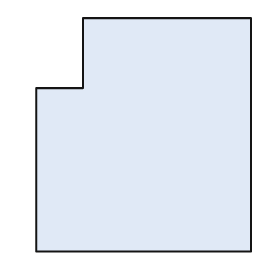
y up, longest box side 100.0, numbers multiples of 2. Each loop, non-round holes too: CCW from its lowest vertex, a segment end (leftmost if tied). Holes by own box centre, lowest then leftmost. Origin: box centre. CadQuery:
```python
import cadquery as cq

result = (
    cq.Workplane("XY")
    .moveTo(-46.0, -50.0)
    .lineTo(46.0, -50.0)
    .lineTo(46.0, 50.0)
    .lineTo(-26.0, 50.0)
    .lineTo(-26.0, 20.0)
    .lineTo(-46.0, 20.0)
    .close()
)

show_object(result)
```